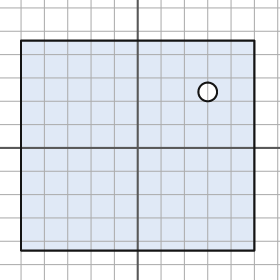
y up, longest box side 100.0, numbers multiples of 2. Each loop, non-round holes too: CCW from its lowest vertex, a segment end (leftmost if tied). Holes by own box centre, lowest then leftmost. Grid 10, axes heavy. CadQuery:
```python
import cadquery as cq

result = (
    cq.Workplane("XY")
    .moveTo(-50.0, -44.0)
    .lineTo(50.0, -44.0)
    .lineTo(50.0, 46.0)
    .lineTo(-50.0, 46.0)
    .close()
    .moveTo(30.0, 24.0)
    .circle(4.0)
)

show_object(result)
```